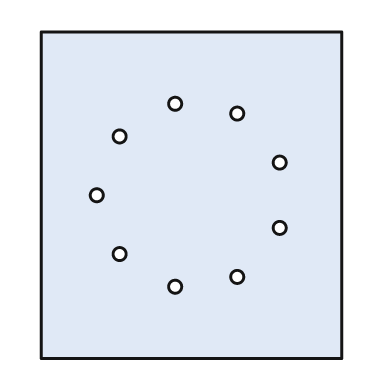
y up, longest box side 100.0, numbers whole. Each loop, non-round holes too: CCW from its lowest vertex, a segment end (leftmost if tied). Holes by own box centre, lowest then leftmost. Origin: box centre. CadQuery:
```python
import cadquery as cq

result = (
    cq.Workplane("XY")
    .moveTo(-46.0, -50.0)
    .lineTo(46.0, -50.0)
    .lineTo(46.0, 50.0)
    .lineTo(-46.0, 50.0)
    .close()
    .moveTo(-5.0, -28.0)
    .circle(2.0)
    .moveTo(14.0, -25.0)
    .circle(2.0)
    .moveTo(-22.0, -18.0)
    .circle(2.0)
    .moveTo(27.0, -10.0)
    .circle(2.0)
    .moveTo(-29.0, 0.0)
    .circle(2.0)
    .moveTo(27.0, 10.0)
    .circle(2.0)
    .moveTo(-22.0, 18.0)
    .circle(2.0)
    .moveTo(14.0, 25.0)
    .circle(2.0)
    .moveTo(-5.0, 28.0)
    .circle(2.0)
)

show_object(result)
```